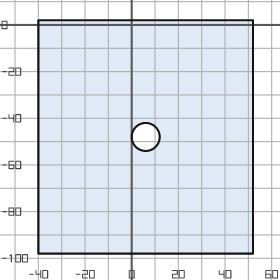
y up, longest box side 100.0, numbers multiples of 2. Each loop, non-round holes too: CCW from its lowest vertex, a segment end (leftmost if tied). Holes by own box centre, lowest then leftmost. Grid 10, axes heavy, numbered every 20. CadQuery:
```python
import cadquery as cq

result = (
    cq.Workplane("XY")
    .moveTo(-40.0, -98.0)
    .lineTo(52.0, -98.0)
    .lineTo(52.0, 2.0)
    .lineTo(-40.0, 2.0)
    .close()
    .moveTo(6.0, -48.0)
    .circle(6.0)
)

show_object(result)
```